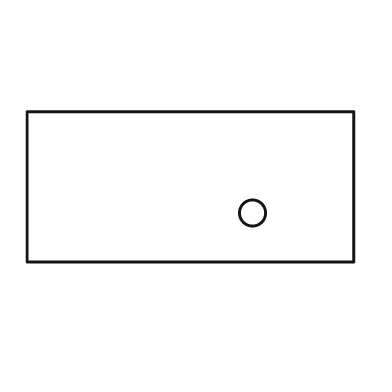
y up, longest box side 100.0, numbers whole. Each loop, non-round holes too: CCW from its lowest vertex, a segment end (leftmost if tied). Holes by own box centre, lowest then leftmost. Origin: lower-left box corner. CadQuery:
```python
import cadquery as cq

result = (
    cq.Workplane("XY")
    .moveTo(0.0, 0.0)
    .lineTo(100.0, 0.0)
    .lineTo(100.0, 46.0)
    .lineTo(0.0, 46.0)
    .close()
    .moveTo(69.0, 15.0)
    .circle(4.0)
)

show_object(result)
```